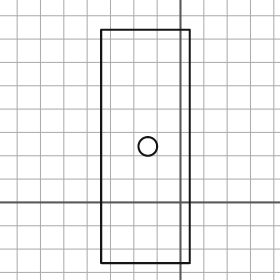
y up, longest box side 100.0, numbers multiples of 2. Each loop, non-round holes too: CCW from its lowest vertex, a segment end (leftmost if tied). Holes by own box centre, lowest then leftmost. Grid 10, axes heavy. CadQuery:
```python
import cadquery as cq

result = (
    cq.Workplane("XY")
    .moveTo(-34.0, -26.0)
    .lineTo(4.0, -26.0)
    .lineTo(4.0, 74.0)
    .lineTo(-34.0, 74.0)
    .close()
    .moveTo(-14.0, 24.0)
    .circle(4.0)
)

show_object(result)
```